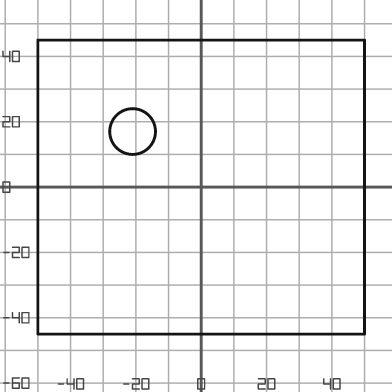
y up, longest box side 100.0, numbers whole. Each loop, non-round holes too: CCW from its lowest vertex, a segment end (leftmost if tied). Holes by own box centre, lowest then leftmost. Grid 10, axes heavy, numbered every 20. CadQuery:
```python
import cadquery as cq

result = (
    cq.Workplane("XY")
    .moveTo(-50.0, -45.0)
    .lineTo(50.0, -45.0)
    .lineTo(50.0, 45.0)
    .lineTo(-50.0, 45.0)
    .close()
    .moveTo(-21.0, 17.0)
    .circle(7.0)
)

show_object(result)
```